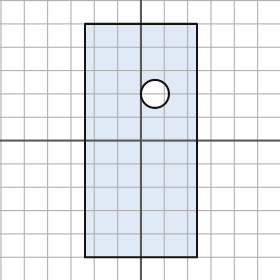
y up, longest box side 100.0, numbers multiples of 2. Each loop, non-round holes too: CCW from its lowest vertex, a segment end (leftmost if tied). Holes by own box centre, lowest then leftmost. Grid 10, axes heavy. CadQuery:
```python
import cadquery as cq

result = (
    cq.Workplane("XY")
    .moveTo(-24.0, -50.0)
    .lineTo(24.0, -50.0)
    .lineTo(24.0, 50.0)
    .lineTo(-24.0, 50.0)
    .close()
    .moveTo(6.0, 20.0)
    .circle(6.0)
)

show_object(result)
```